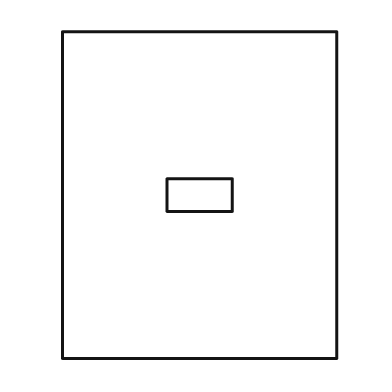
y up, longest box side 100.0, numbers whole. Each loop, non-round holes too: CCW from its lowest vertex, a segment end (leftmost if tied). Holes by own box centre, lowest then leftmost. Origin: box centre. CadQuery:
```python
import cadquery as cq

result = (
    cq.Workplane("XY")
    .moveTo(-42.0, -50.0)
    .lineTo(42.0, -50.0)
    .lineTo(42.0, 50.0)
    .lineTo(-42.0, 50.0)
    .close()
    .moveTo(-10.0, -5.0)
    .lineTo(10.0, -5.0)
    .lineTo(10.0, 5.0)
    .lineTo(-10.0, 5.0)
    .close()
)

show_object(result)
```